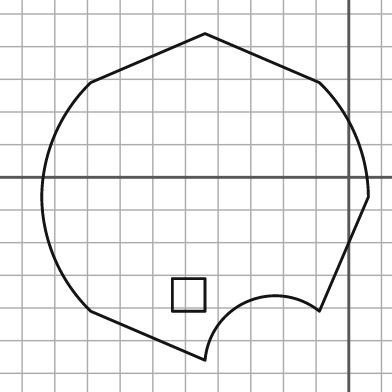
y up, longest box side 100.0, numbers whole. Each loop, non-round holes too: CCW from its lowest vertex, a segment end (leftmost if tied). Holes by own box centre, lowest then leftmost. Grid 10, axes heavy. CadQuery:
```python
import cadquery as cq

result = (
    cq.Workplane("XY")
    .moveTo(-44.0, -56.0)
    .threePointArc((-31.0, -38.0), (-9.0, -41.0))
    .lineTo(6.0, -6.0)
    .threePointArc((2.0, 13.0), (-9.0, 29.0))
    .lineTo(-44.0, 44.0)
    .lineTo(-79.0, 29.0)
    .threePointArc((-90.0, 13.0), (-94.0, -6.0))
    .threePointArc((-90.0, -25.0), (-79.0, -41.0))
    .close()
    .moveTo(-54.0, -41.0)
    .lineTo(-44.0, -41.0)
    .lineTo(-44.0, -31.0)
    .lineTo(-54.0, -31.0)
    .close()
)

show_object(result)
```